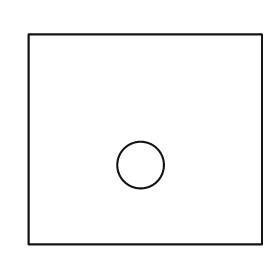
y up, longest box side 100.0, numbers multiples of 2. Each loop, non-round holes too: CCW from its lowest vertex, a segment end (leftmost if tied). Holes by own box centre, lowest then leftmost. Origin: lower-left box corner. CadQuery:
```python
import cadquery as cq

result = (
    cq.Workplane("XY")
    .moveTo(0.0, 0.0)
    .lineTo(100.0, 0.0)
    .lineTo(100.0, 90.0)
    .lineTo(0.0, 90.0)
    .close()
    .moveTo(48.0, 34.0)
    .circle(10.0)
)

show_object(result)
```